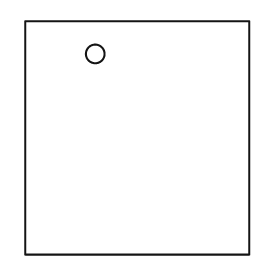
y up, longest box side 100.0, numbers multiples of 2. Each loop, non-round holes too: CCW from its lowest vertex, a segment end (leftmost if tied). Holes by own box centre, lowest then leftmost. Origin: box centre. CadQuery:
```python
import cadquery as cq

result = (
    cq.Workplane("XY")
    .moveTo(-48.0, -50.0)
    .lineTo(48.0, -50.0)
    .lineTo(48.0, 50.0)
    .lineTo(-48.0, 50.0)
    .close()
    .moveTo(-18.0, 36.0)
    .circle(4.0)
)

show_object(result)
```